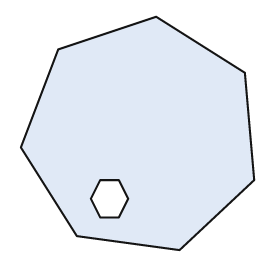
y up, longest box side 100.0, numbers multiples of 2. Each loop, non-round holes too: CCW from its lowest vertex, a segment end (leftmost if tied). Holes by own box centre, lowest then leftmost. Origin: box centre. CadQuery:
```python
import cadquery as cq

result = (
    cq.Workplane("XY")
    .moveTo(18.0, -50.0)
    .lineTo(50.0, -20.0)
    .lineTo(46.0, 26.0)
    .lineTo(8.0, 50.0)
    .lineTo(-34.0, 36.0)
    .lineTo(-50.0, -6.0)
    .lineTo(-26.0, -44.0)
    .close()
    .moveTo(-16.0, -36.0)
    .lineTo(-8.0, -36.0)
    .lineTo(-4.0, -28.0)
    .lineTo(-8.0, -20.0)
    .lineTo(-16.0, -20.0)
    .lineTo(-20.0, -28.0)
    .close()
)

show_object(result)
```